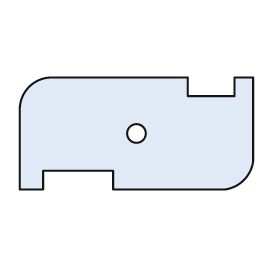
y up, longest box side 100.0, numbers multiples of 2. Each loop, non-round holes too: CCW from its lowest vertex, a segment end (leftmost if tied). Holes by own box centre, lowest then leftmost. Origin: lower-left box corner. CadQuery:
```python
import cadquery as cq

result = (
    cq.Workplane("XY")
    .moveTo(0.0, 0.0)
    .lineTo(10.0, 0.0)
    .lineTo(10.0, 8.0)
    .lineTo(40.0, 8.0)
    .lineTo(40.0, 0.0)
    .lineTo(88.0, 0.0)
    .threePointArc((96.0, 4.0), (100.0, 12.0))
    .lineTo(100.0, 48.0)
    .lineTo(92.0, 48.0)
    .lineTo(92.0, 40.0)
    .lineTo(72.0, 40.0)
    .lineTo(72.0, 48.0)
    .lineTo(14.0, 48.0)
    .threePointArc((4.0, 44.0), (0.0, 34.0))
    .close()
    .moveTo(50.0, 24.0)
    .circle(4.0)
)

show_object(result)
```